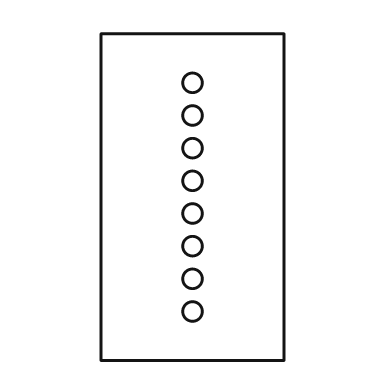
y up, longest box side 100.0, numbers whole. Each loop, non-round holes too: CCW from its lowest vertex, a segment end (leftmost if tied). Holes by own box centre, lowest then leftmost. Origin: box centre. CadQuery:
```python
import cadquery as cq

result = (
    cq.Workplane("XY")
    .moveTo(-28.0, -50.0)
    .lineTo(28.0, -50.0)
    .lineTo(28.0, 50.0)
    .lineTo(-28.0, 50.0)
    .close()
    .moveTo(0.0, -35.0)
    .circle(3.0)
    .moveTo(0.0, -25.0)
    .circle(3.0)
    .moveTo(0.0, -15.0)
    .circle(3.0)
    .moveTo(0.0, -5.0)
    .circle(3.0)
    .moveTo(0.0, 5.0)
    .circle(3.0)
    .moveTo(0.0, 15.0)
    .circle(3.0)
    .moveTo(0.0, 25.0)
    .circle(3.0)
    .moveTo(0.0, 35.0)
    .circle(3.0)
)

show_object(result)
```